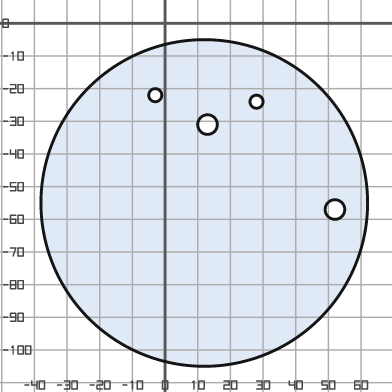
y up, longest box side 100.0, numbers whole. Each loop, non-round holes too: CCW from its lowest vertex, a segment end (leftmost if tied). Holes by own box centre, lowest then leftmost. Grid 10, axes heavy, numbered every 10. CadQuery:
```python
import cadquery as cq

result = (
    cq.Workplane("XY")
    .moveTo(12.0, -55.0)
    .circle(50.0)
    .moveTo(52.0, -57.0)
    .circle(3.0)
    .moveTo(13.0, -31.0)
    .circle(3.0)
    .moveTo(28.0, -24.0)
    .circle(2.0)
    .moveTo(-3.0, -22.0)
    .circle(2.0)
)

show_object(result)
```